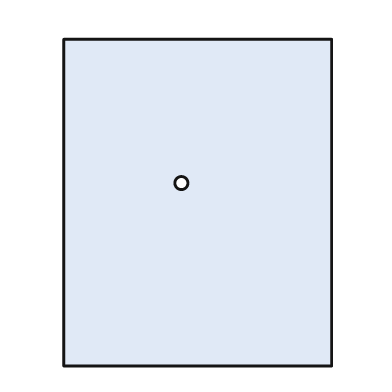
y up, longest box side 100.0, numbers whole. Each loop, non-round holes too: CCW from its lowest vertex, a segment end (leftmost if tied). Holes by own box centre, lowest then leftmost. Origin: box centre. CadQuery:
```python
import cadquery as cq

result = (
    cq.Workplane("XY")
    .moveTo(-41.0, -50.0)
    .lineTo(41.0, -50.0)
    .lineTo(41.0, 50.0)
    .lineTo(-41.0, 50.0)
    .close()
    .moveTo(-5.0, 6.0)
    .circle(2.0)
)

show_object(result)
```